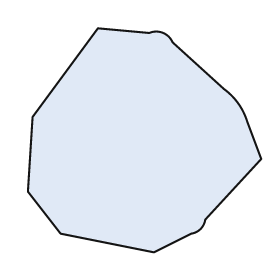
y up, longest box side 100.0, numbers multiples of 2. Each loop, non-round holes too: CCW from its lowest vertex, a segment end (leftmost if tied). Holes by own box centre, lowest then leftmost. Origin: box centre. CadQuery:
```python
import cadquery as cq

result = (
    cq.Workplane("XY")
    .moveTo(4.0, -48.0)
    .lineTo(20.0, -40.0)
    .threePointArc((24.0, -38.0), (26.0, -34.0))
    .lineTo(50.0, -8.0)
    .lineTo(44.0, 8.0)
    .threePointArc((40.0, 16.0), (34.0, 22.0))
    .lineTo(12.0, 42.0)
    .threePointArc((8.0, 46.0), (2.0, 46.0))
    .lineTo(-20.0, 48.0)
    .lineTo(-48.0, 10.0)
    .lineTo(-50.0, -22.0)
    .lineTo(-36.0, -40.0)
    .close()
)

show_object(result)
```